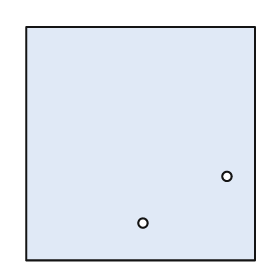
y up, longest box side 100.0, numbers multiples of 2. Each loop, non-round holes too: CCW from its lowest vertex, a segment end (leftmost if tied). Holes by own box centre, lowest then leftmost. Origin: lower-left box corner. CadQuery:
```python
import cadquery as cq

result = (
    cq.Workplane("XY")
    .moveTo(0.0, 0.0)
    .lineTo(98.0, 0.0)
    .lineTo(98.0, 100.0)
    .lineTo(0.0, 100.0)
    .close()
    .moveTo(50.0, 16.0)
    .circle(2.0)
    .moveTo(86.0, 36.0)
    .circle(2.0)
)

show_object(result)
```